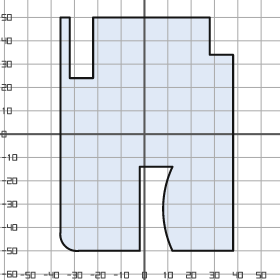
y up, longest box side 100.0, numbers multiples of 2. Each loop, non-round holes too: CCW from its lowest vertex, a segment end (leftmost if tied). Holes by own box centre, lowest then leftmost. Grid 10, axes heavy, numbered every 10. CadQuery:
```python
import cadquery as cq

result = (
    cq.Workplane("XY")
    .moveTo(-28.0, -50.0)
    .lineTo(-2.0, -50.0)
    .lineTo(-2.0, -14.0)
    .lineTo(12.0, -14.0)
    .threePointArc((8.0, -32.0), (12.0, -50.0))
    .lineTo(38.0, -50.0)
    .lineTo(38.0, 34.0)
    .lineTo(28.0, 34.0)
    .lineTo(28.0, 50.0)
    .lineTo(-22.0, 50.0)
    .lineTo(-22.0, 24.0)
    .lineTo(-32.0, 24.0)
    .lineTo(-32.0, 50.0)
    .lineTo(-36.0, 50.0)
    .lineTo(-36.0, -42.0)
    .threePointArc((-34.0, -48.0), (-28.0, -50.0))
    .close()
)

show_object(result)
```